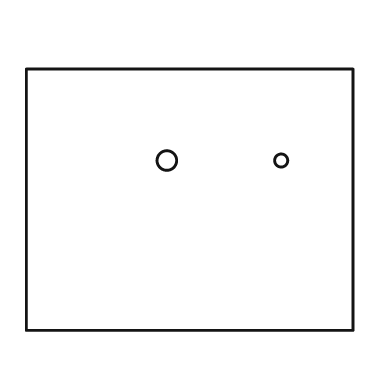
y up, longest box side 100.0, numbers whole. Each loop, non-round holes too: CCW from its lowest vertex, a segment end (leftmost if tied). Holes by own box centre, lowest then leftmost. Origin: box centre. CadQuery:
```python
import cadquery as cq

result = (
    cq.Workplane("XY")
    .moveTo(-50.0, -40.0)
    .lineTo(50.0, -40.0)
    .lineTo(50.0, 40.0)
    .lineTo(-50.0, 40.0)
    .close()
    .moveTo(-7.0, 12.0)
    .circle(3.0)
    .moveTo(28.0, 12.0)
    .circle(2.0)
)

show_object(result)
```